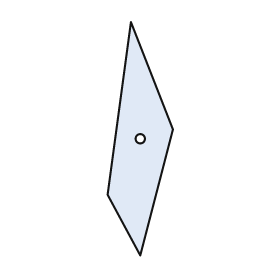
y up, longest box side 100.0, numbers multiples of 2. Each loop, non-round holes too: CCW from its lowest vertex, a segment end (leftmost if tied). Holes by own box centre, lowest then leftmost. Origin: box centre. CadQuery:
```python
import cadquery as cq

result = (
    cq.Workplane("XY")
    .moveTo(0.0, -50.0)
    .lineTo(14.0, 4.0)
    .lineTo(-4.0, 50.0)
    .lineTo(-14.0, -24.0)
    .close()
    .moveTo(0.0, 0.0)
    .circle(2.0)
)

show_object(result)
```